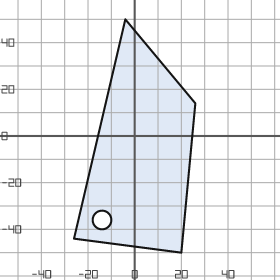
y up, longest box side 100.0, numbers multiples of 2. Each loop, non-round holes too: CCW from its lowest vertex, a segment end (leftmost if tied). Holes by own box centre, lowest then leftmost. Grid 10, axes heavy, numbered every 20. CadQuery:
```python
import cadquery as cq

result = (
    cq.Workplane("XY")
    .moveTo(20.0, -50.0)
    .lineTo(26.0, 14.0)
    .lineTo(-4.0, 50.0)
    .lineTo(-26.0, -44.0)
    .close()
    .moveTo(-14.0, -36.0)
    .circle(4.0)
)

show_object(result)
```